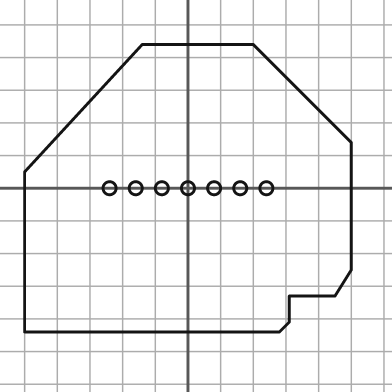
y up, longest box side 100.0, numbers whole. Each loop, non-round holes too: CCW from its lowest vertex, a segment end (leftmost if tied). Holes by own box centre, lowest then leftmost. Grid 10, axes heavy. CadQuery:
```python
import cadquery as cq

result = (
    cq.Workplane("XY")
    .moveTo(-50.0, -44.0)
    .lineTo(28.0, -44.0)
    .lineTo(31.0, -41.0)
    .lineTo(31.0, -33.0)
    .lineTo(45.0, -33.0)
    .lineTo(50.0, -25.0)
    .lineTo(50.0, 14.0)
    .lineTo(20.0, 44.0)
    .lineTo(-14.0, 44.0)
    .lineTo(-50.0, 5.0)
    .close()
    .moveTo(-24.0, 0.0)
    .circle(2.0)
    .moveTo(-16.0, 0.0)
    .circle(2.0)
    .moveTo(-8.0, 0.0)
    .circle(2.0)
    .moveTo(0.0, 0.0)
    .circle(2.0)
    .moveTo(8.0, 0.0)
    .circle(2.0)
    .moveTo(16.0, 0.0)
    .circle(2.0)
    .moveTo(24.0, 0.0)
    .circle(2.0)
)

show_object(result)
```